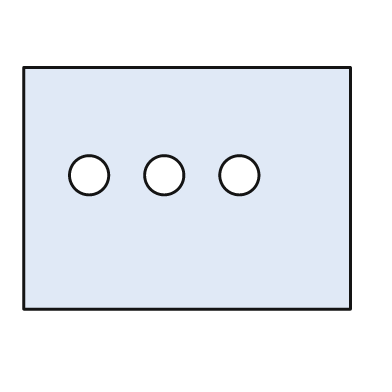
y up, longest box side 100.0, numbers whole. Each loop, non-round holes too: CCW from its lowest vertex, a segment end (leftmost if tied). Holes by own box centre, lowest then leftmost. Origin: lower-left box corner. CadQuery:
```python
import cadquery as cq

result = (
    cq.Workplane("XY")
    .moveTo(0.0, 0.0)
    .lineTo(100.0, 0.0)
    .lineTo(100.0, 74.0)
    .lineTo(0.0, 74.0)
    .close()
    .moveTo(20.0, 41.0)
    .circle(6.0)
    .moveTo(43.0, 41.0)
    .circle(6.0)
    .moveTo(66.0, 41.0)
    .circle(6.0)
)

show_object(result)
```